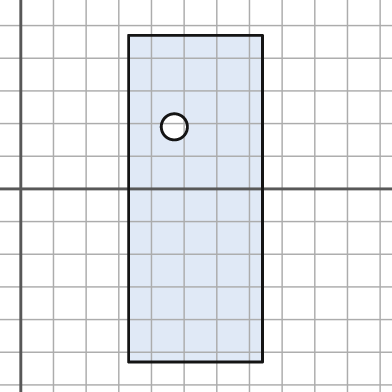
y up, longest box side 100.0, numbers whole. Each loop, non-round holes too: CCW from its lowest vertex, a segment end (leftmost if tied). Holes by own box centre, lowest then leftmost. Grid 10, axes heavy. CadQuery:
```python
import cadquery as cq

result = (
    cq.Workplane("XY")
    .moveTo(33.0, -53.0)
    .lineTo(74.0, -53.0)
    .lineTo(74.0, 47.0)
    .lineTo(33.0, 47.0)
    .close()
    .moveTo(47.0, 19.0)
    .circle(4.0)
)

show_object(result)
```